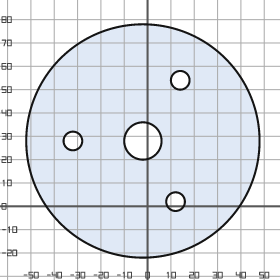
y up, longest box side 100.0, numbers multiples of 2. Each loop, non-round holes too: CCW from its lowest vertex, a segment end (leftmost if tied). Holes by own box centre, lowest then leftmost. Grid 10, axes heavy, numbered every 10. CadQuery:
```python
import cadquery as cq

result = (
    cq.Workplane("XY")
    .moveTo(-2.0, 28.0)
    .circle(50.0)
    .moveTo(12.0, 2.0)
    .circle(4.0)
    .moveTo(-32.0, 28.0)
    .circle(4.0)
    .moveTo(-2.0, 28.0)
    .circle(8.0)
    .moveTo(14.0, 54.0)
    .circle(4.0)
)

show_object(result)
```